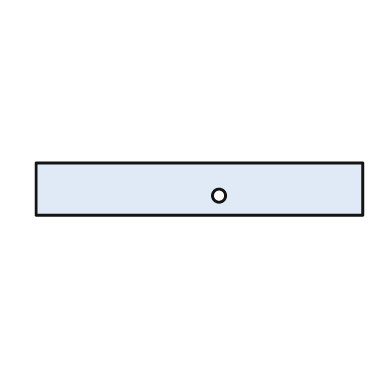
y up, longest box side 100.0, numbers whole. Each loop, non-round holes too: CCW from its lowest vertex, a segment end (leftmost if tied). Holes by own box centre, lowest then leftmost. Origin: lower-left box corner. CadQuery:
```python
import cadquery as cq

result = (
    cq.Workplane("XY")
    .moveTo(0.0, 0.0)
    .lineTo(100.0, 0.0)
    .lineTo(100.0, 16.0)
    .lineTo(0.0, 16.0)
    .close()
    .moveTo(56.0, 6.0)
    .circle(2.0)
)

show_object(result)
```